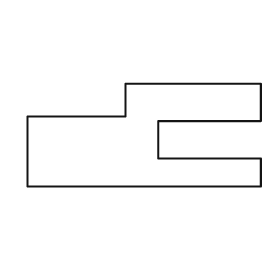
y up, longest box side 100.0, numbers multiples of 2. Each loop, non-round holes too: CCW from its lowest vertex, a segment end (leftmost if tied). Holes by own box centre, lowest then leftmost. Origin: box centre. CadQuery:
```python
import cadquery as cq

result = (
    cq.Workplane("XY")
    .moveTo(-50.0, -22.0)
    .lineTo(50.0, -22.0)
    .lineTo(50.0, -10.0)
    .lineTo(6.0, -10.0)
    .lineTo(6.0, 6.0)
    .lineTo(50.0, 6.0)
    .lineTo(50.0, 22.0)
    .lineTo(-8.0, 22.0)
    .lineTo(-8.0, 8.0)
    .lineTo(-50.0, 8.0)
    .close()
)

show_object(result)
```